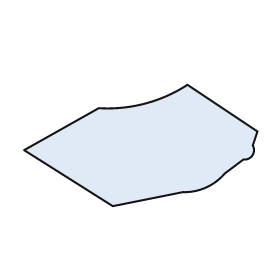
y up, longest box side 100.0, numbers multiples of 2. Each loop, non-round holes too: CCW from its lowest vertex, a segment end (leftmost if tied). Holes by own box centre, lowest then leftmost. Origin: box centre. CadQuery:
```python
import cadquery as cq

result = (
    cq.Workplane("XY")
    .moveTo(-12.0, -26.0)
    .lineTo(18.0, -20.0)
    .threePointArc((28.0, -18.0), (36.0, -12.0))
    .lineTo(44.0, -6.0)
    .threePointArc((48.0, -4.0), (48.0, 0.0))
    .lineTo(50.0, 6.0)
    .lineTo(20.0, 26.0)
    .threePointArc((2.0, 18.0), (-18.0, 16.0))
    .lineTo(-50.0, -2.0)
    .close()
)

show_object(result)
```